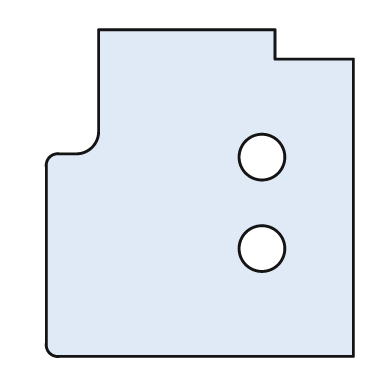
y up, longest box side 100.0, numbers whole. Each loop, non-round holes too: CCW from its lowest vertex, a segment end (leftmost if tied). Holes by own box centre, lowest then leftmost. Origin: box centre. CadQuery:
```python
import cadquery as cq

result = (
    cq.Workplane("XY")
    .moveTo(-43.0, -50.0)
    .lineTo(47.0, -50.0)
    .lineTo(47.0, 41.0)
    .lineTo(23.0, 41.0)
    .lineTo(23.0, 50.0)
    .lineTo(-31.0, 50.0)
    .lineTo(-31.0, 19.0)
    .threePointArc((-33.0, 14.0), (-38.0, 12.0))
    .lineTo(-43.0, 12.0)
    .threePointArc((-46.0, 11.0), (-47.0, 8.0))
    .lineTo(-47.0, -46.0)
    .threePointArc((-46.0, -49.0), (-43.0, -50.0))
    .close()
    .moveTo(19.0, -17.0)
    .circle(7.0)
    .moveTo(19.0, 11.0)
    .circle(7.0)
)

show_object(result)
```